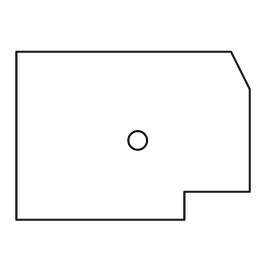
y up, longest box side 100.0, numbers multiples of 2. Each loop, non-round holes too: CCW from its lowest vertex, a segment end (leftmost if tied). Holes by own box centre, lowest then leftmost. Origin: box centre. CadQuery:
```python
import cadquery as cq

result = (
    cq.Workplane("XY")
    .moveTo(-50.0, -36.0)
    .lineTo(22.0, -36.0)
    .lineTo(22.0, -24.0)
    .lineTo(50.0, -24.0)
    .lineTo(50.0, 20.0)
    .lineTo(42.0, 36.0)
    .lineTo(-50.0, 36.0)
    .close()
    .moveTo(2.0, -2.0)
    .circle(4.0)
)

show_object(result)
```